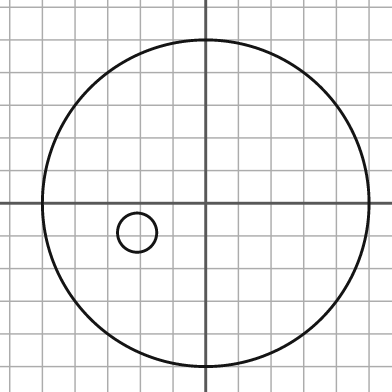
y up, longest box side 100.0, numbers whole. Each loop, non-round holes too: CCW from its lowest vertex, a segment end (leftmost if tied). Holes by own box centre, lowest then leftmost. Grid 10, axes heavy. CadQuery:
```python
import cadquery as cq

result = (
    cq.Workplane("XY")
    .moveTo(0.0, 0.0)
    .circle(50.0)
    .moveTo(-21.0, -9.0)
    .circle(6.0)
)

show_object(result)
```